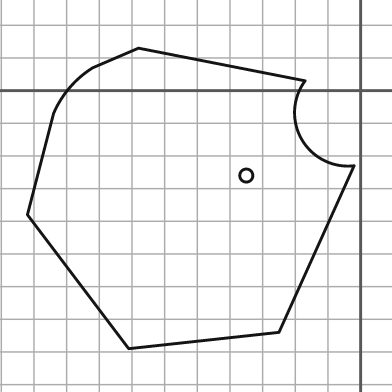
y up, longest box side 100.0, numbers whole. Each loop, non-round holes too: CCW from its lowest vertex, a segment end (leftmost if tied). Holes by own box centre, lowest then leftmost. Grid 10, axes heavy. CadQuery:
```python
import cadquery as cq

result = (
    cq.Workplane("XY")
    .moveTo(-71.0, -79.0)
    .lineTo(-25.0, -74.0)
    .lineTo(-2.0, -23.0)
    .threePointArc((-18.0, -15.0), (-17.0, 3.0))
    .lineTo(-68.0, 13.0)
    .lineTo(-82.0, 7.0)
    .threePointArc((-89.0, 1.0), (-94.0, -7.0))
    .lineTo(-102.0, -38.0)
    .close()
    .moveTo(-35.0, -26.0)
    .circle(2.0)
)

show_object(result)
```